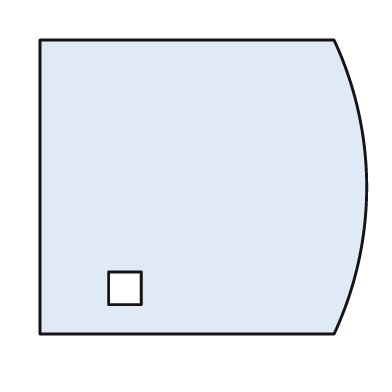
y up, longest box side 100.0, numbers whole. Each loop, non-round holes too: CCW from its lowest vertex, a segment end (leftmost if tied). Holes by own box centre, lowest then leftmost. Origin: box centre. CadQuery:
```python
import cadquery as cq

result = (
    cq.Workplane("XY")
    .moveTo(-50.0, -45.0)
    .lineTo(40.0, -45.0)
    .threePointArc((50.0, 0.0), (40.0, 45.0))
    .lineTo(-50.0, 45.0)
    .close()
    .moveTo(-29.0, -36.0)
    .lineTo(-19.0, -36.0)
    .lineTo(-19.0, -26.0)
    .lineTo(-29.0, -26.0)
    .close()
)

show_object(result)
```